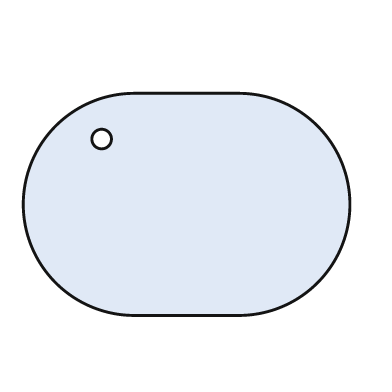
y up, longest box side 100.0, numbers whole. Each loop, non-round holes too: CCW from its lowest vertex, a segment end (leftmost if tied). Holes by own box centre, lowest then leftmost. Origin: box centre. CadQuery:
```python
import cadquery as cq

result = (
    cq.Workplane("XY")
    .moveTo(-16.0, -34.0)
    .lineTo(16.0, -34.0)
    .threePointArc((50.0, 0.0), (16.0, 34.0))
    .lineTo(-16.0, 34.0)
    .threePointArc((-50.0, 0.0), (-16.0, -34.0))
    .close()
    .moveTo(-26.0, 20.0)
    .circle(3.0)
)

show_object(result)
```